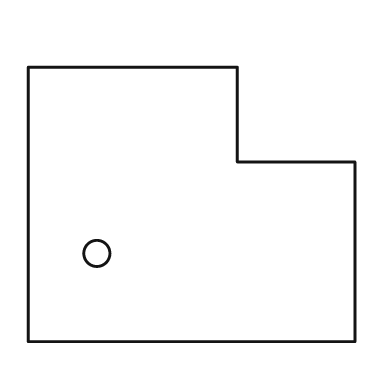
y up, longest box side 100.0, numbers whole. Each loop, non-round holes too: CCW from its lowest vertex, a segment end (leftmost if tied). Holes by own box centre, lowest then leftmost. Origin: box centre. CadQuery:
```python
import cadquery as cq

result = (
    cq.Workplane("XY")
    .moveTo(-50.0, -42.0)
    .lineTo(50.0, -42.0)
    .lineTo(50.0, 13.0)
    .lineTo(14.0, 13.0)
    .lineTo(14.0, 42.0)
    .lineTo(-50.0, 42.0)
    .close()
    .moveTo(-29.0, -15.0)
    .circle(4.0)
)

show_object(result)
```